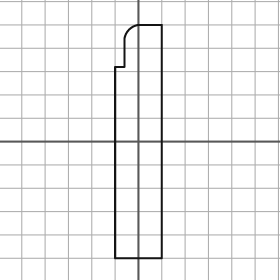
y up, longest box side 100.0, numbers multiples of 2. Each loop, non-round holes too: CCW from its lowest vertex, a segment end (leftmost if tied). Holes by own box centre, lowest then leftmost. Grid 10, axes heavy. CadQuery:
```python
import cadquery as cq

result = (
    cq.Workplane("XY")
    .moveTo(-10.0, -50.0)
    .lineTo(10.0, -50.0)
    .lineTo(10.0, 50.0)
    .lineTo(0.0, 50.0)
    .threePointArc((-4.0, 48.0), (-6.0, 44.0))
    .lineTo(-6.0, 32.0)
    .lineTo(-10.0, 32.0)
    .close()
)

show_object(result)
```